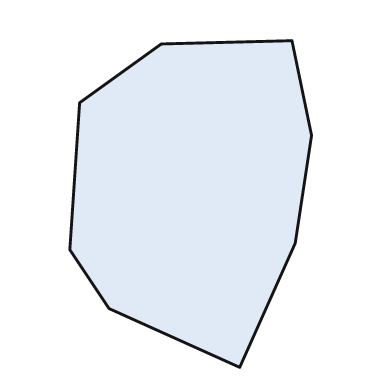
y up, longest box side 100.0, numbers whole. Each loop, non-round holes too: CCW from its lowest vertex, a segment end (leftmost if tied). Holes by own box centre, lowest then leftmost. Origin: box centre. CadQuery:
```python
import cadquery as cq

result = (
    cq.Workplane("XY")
    .moveTo(15.0, -50.0)
    .lineTo(32.0, -12.0)
    .lineTo(37.0, 21.0)
    .lineTo(31.0, 50.0)
    .lineTo(-9.0, 49.0)
    .lineTo(-34.0, 31.0)
    .lineTo(-37.0, -14.0)
    .lineTo(-25.0, -32.0)
    .close()
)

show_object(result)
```